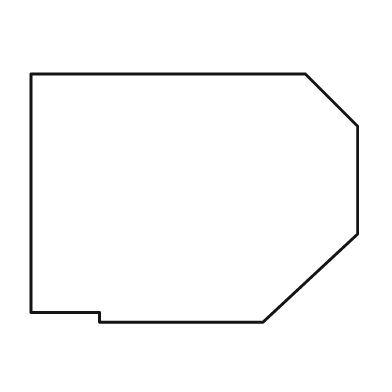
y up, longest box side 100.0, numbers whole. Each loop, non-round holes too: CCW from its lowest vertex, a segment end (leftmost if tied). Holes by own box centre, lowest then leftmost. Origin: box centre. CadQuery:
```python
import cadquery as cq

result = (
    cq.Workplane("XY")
    .moveTo(-29.0, -38.0)
    .lineTo(21.0, -38.0)
    .lineTo(50.0, -11.0)
    .lineTo(50.0, 22.0)
    .lineTo(34.0, 38.0)
    .lineTo(-50.0, 38.0)
    .lineTo(-50.0, -35.0)
    .lineTo(-29.0, -35.0)
    .close()
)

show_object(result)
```